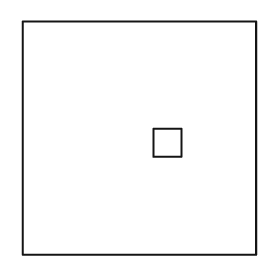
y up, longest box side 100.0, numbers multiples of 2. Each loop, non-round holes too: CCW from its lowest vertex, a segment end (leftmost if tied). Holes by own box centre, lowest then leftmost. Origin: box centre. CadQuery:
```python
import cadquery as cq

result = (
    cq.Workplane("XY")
    .moveTo(-50.0, -50.0)
    .lineTo(50.0, -50.0)
    .lineTo(50.0, 50.0)
    .lineTo(-50.0, 50.0)
    .close()
    .moveTo(6.0, -8.0)
    .lineTo(18.0, -8.0)
    .lineTo(18.0, 4.0)
    .lineTo(6.0, 4.0)
    .close()
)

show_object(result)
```